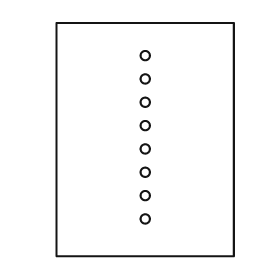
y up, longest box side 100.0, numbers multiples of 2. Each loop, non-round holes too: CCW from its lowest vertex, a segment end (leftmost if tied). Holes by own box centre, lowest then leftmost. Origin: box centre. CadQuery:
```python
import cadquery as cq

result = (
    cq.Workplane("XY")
    .moveTo(-38.0, -50.0)
    .lineTo(38.0, -50.0)
    .lineTo(38.0, 50.0)
    .lineTo(-38.0, 50.0)
    .close()
    .moveTo(0.0, -34.0)
    .circle(2.0)
    .moveTo(0.0, -24.0)
    .circle(2.0)
    .moveTo(0.0, -14.0)
    .circle(2.0)
    .moveTo(0.0, -4.0)
    .circle(2.0)
    .moveTo(0.0, 6.0)
    .circle(2.0)
    .moveTo(0.0, 16.0)
    .circle(2.0)
    .moveTo(0.0, 26.0)
    .circle(2.0)
    .moveTo(0.0, 36.0)
    .circle(2.0)
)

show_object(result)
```